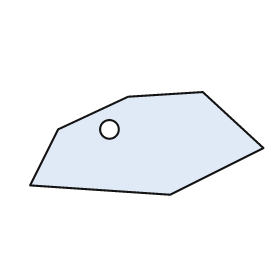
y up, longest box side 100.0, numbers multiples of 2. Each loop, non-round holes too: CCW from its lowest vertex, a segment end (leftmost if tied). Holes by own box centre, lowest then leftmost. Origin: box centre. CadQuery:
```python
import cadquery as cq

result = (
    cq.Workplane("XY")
    .moveTo(10.0, -22.0)
    .lineTo(50.0, -2.0)
    .lineTo(24.0, 22.0)
    .lineTo(-8.0, 20.0)
    .lineTo(-38.0, 6.0)
    .lineTo(-50.0, -18.0)
    .close()
    .moveTo(-16.0, 6.0)
    .circle(4.0)
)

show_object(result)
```